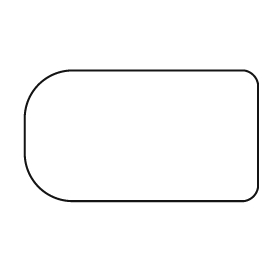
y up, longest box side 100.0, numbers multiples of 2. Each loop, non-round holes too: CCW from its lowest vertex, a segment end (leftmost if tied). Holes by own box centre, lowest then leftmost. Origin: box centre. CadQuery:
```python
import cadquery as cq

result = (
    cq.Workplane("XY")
    .moveTo(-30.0, -28.0)
    .lineTo(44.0, -28.0)
    .threePointArc((48.0, -26.0), (50.0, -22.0))
    .lineTo(50.0, 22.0)
    .threePointArc((48.0, 26.0), (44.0, 28.0))
    .lineTo(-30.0, 28.0)
    .threePointArc((-44.0, 22.0), (-50.0, 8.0))
    .lineTo(-50.0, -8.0)
    .threePointArc((-44.0, -22.0), (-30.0, -28.0))
    .close()
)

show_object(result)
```